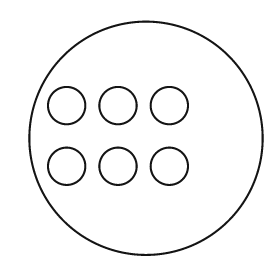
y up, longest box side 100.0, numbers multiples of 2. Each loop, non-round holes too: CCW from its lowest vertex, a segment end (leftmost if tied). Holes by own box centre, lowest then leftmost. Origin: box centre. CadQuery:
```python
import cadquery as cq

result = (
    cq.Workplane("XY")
    .moveTo(0.0, 0.0)
    .circle(50.0)
    .moveTo(-34.0, -12.0)
    .circle(8.0)
    .moveTo(-12.0, -12.0)
    .circle(8.0)
    .moveTo(10.0, -12.0)
    .circle(8.0)
    .moveTo(-34.0, 14.0)
    .circle(8.0)
    .moveTo(-12.0, 14.0)
    .circle(8.0)
    .moveTo(10.0, 14.0)
    .circle(8.0)
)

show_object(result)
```